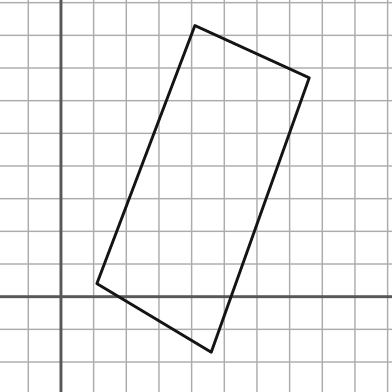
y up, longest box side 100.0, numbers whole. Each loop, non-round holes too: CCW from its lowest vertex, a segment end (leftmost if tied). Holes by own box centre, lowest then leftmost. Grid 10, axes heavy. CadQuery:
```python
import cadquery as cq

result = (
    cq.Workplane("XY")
    .moveTo(46.0, -17.0)
    .lineTo(76.0, 67.0)
    .lineTo(41.0, 83.0)
    .lineTo(11.0, 4.0)
    .close()
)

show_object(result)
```